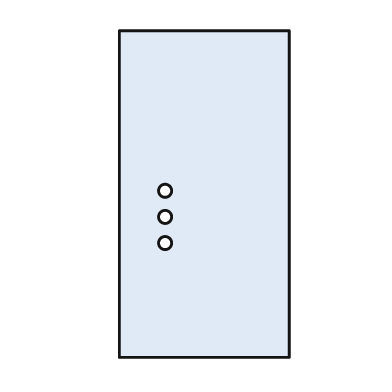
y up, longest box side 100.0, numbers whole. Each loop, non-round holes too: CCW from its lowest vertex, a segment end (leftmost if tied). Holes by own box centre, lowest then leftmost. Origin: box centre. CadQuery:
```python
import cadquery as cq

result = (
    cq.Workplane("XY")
    .moveTo(-26.0, -50.0)
    .lineTo(26.0, -50.0)
    .lineTo(26.0, 50.0)
    .lineTo(-26.0, 50.0)
    .close()
    .moveTo(-12.0, -15.0)
    .circle(2.0)
    .moveTo(-12.0, -7.0)
    .circle(2.0)
    .moveTo(-12.0, 1.0)
    .circle(2.0)
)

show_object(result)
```